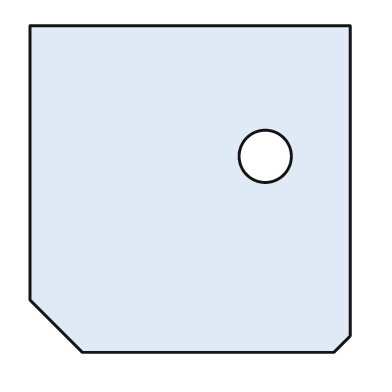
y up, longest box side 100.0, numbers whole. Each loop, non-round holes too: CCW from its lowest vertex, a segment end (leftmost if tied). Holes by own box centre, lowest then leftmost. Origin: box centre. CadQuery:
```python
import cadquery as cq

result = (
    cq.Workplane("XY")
    .moveTo(-33.0, -50.0)
    .lineTo(44.0, -50.0)
    .lineTo(49.0, -45.0)
    .lineTo(49.0, 50.0)
    .lineTo(-49.0, 50.0)
    .lineTo(-49.0, -34.0)
    .close()
    .moveTo(23.0, 10.0)
    .circle(8.0)
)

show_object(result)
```